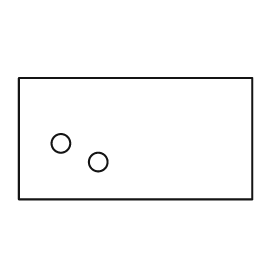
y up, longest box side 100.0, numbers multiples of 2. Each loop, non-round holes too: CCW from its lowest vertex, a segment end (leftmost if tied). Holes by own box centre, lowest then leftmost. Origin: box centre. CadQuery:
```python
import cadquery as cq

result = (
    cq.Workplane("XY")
    .moveTo(-50.0, -26.0)
    .lineTo(50.0, -26.0)
    .lineTo(50.0, 26.0)
    .lineTo(-50.0, 26.0)
    .close()
    .moveTo(-16.0, -10.0)
    .circle(4.0)
    .moveTo(-32.0, -2.0)
    .circle(4.0)
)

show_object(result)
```